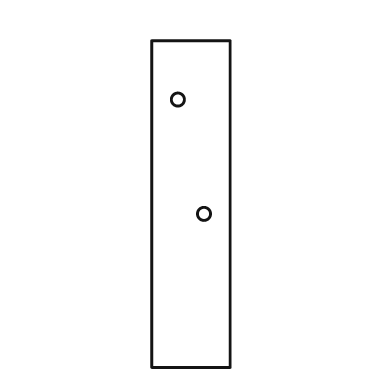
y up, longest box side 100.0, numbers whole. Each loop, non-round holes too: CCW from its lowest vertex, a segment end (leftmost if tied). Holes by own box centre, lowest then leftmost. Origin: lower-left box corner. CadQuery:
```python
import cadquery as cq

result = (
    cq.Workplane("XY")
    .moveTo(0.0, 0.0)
    .lineTo(24.0, 0.0)
    .lineTo(24.0, 100.0)
    .lineTo(0.0, 100.0)
    .close()
    .moveTo(16.0, 47.0)
    .circle(2.0)
    .moveTo(8.0, 82.0)
    .circle(2.0)
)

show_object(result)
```